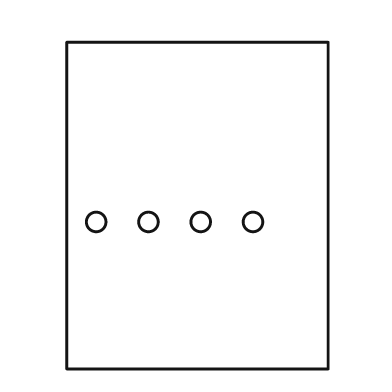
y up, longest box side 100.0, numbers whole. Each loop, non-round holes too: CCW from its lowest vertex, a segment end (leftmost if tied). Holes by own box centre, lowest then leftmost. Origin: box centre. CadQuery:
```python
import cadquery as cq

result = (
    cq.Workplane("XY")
    .moveTo(-40.0, -50.0)
    .lineTo(40.0, -50.0)
    .lineTo(40.0, 50.0)
    .lineTo(-40.0, 50.0)
    .close()
    .moveTo(-31.0, -5.0)
    .circle(3.0)
    .moveTo(-15.0, -5.0)
    .circle(3.0)
    .moveTo(1.0, -5.0)
    .circle(3.0)
    .moveTo(17.0, -5.0)
    .circle(3.0)
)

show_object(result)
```